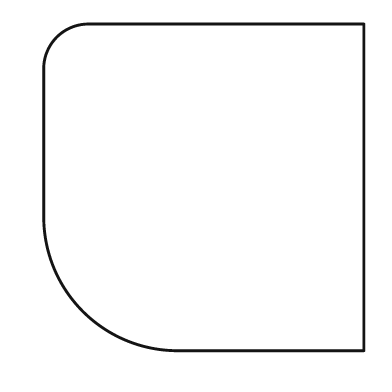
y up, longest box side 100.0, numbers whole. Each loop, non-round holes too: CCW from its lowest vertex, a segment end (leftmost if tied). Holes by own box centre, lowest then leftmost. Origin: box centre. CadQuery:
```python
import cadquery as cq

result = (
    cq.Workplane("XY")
    .moveTo(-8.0, -50.0)
    .lineTo(49.0, -50.0)
    .lineTo(49.0, 50.0)
    .lineTo(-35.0, 50.0)
    .threePointArc((-45.0, 46.0), (-49.0, 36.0))
    .lineTo(-49.0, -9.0)
    .threePointArc((-37.0, -38.0), (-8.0, -50.0))
    .close()
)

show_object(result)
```